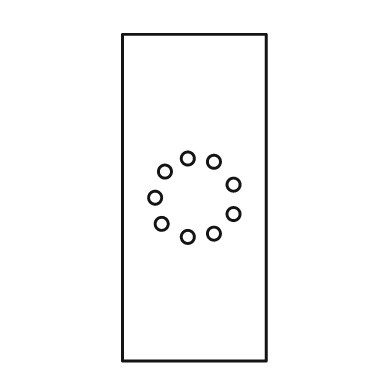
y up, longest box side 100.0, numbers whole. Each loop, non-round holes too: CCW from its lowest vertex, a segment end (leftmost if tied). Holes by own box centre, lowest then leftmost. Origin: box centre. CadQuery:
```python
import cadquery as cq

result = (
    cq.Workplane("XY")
    .moveTo(-22.0, -50.0)
    .lineTo(22.0, -50.0)
    .lineTo(22.0, 50.0)
    .lineTo(-22.0, 50.0)
    .close()
    .moveTo(-2.0, -12.0)
    .circle(2.0)
    .moveTo(6.0, -11.0)
    .circle(2.0)
    .moveTo(-10.0, -8.0)
    .circle(2.0)
    .moveTo(12.0, -5.0)
    .circle(2.0)
    .moveTo(-12.0, 0.0)
    .circle(2.0)
    .moveTo(12.0, 4.0)
    .circle(2.0)
    .moveTo(-9.0, 8.0)
    .circle(2.0)
    .moveTo(6.0, 11.0)
    .circle(2.0)
    .moveTo(-2.0, 12.0)
    .circle(2.0)
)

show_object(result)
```